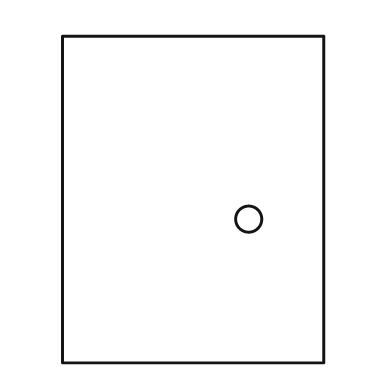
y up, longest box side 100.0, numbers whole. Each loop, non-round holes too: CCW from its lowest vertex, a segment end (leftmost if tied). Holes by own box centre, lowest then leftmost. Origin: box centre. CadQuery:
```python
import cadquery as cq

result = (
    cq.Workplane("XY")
    .moveTo(-40.0, -50.0)
    .lineTo(40.0, -50.0)
    .lineTo(40.0, 50.0)
    .lineTo(-40.0, 50.0)
    .close()
    .moveTo(17.0, -6.0)
    .circle(4.0)
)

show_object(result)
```